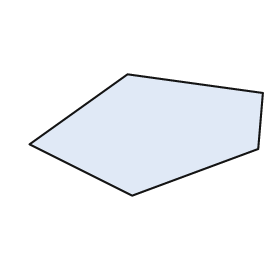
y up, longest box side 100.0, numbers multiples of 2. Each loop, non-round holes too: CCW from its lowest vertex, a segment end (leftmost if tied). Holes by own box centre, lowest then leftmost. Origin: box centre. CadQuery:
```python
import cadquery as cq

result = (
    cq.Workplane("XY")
    .moveTo(-6.0, -26.0)
    .lineTo(48.0, -6.0)
    .lineTo(50.0, 18.0)
    .lineTo(-8.0, 26.0)
    .lineTo(-50.0, -4.0)
    .close()
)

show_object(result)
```